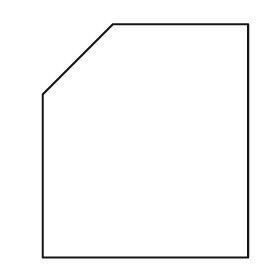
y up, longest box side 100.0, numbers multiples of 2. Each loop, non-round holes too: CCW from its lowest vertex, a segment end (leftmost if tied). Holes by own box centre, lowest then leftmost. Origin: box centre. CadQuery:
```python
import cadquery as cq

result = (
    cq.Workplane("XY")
    .moveTo(-44.0, -50.0)
    .lineTo(44.0, -50.0)
    .lineTo(44.0, 50.0)
    .lineTo(-14.0, 50.0)
    .lineTo(-44.0, 20.0)
    .close()
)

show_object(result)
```